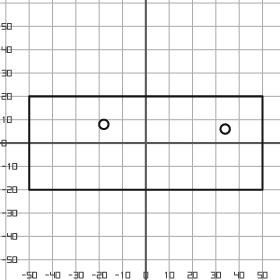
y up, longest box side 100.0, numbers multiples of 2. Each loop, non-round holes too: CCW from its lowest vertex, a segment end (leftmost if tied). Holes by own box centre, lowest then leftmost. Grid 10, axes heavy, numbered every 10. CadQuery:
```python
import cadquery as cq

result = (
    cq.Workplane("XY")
    .moveTo(-50.0, -20.0)
    .lineTo(50.0, -20.0)
    .lineTo(50.0, 20.0)
    .lineTo(-50.0, 20.0)
    .close()
    .moveTo(34.0, 6.0)
    .circle(2.0)
    .moveTo(-18.0, 8.0)
    .circle(2.0)
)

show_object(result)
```